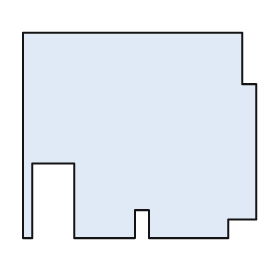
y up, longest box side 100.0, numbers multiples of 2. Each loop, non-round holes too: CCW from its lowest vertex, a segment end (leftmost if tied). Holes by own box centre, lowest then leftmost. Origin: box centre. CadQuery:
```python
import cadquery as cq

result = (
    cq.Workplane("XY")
    .moveTo(-50.0, -44.0)
    .lineTo(-46.0, -44.0)
    .lineTo(-46.0, -12.0)
    .lineTo(-28.0, -12.0)
    .lineTo(-28.0, -44.0)
    .lineTo(-2.0, -44.0)
    .lineTo(-2.0, -32.0)
    .lineTo(4.0, -32.0)
    .lineTo(4.0, -44.0)
    .lineTo(38.0, -44.0)
    .lineTo(38.0, -36.0)
    .lineTo(50.0, -36.0)
    .lineTo(50.0, 22.0)
    .lineTo(44.0, 22.0)
    .lineTo(44.0, 44.0)
    .lineTo(-50.0, 44.0)
    .close()
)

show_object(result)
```